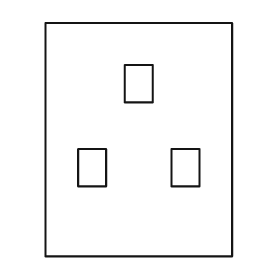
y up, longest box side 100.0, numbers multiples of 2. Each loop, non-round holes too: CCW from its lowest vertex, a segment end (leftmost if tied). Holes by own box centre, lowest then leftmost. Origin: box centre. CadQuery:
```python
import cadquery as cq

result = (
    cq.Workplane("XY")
    .moveTo(-40.0, -50.0)
    .lineTo(40.0, -50.0)
    .lineTo(40.0, 50.0)
    .lineTo(-40.0, 50.0)
    .close()
    .moveTo(-26.0, -20.0)
    .lineTo(-14.0, -20.0)
    .lineTo(-14.0, -4.0)
    .lineTo(-26.0, -4.0)
    .close()
    .moveTo(14.0, -20.0)
    .lineTo(26.0, -20.0)
    .lineTo(26.0, -4.0)
    .lineTo(14.0, -4.0)
    .close()
    .moveTo(-6.0, 16.0)
    .lineTo(6.0, 16.0)
    .lineTo(6.0, 32.0)
    .lineTo(-6.0, 32.0)
    .close()
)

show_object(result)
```